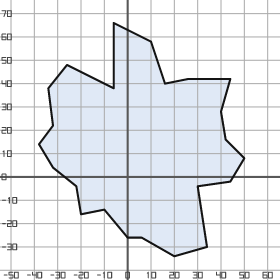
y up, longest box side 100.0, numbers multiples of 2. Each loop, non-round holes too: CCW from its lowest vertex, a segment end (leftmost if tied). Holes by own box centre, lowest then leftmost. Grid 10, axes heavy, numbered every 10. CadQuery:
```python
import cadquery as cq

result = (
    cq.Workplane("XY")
    .moveTo(20.0, -34.0)
    .lineTo(34.0, -30.0)
    .lineTo(30.0, -4.0)
    .lineTo(44.0, -2.0)
    .lineTo(50.0, 8.0)
    .lineTo(42.0, 16.0)
    .lineTo(40.0, 28.0)
    .lineTo(44.0, 42.0)
    .lineTo(26.0, 42.0)
    .lineTo(16.0, 40.0)
    .lineTo(10.0, 58.0)
    .lineTo(-6.0, 66.0)
    .lineTo(-6.0, 38.0)
    .lineTo(-26.0, 48.0)
    .lineTo(-34.0, 38.0)
    .lineTo(-32.0, 22.0)
    .lineTo(-38.0, 14.0)
    .lineTo(-32.0, 4.0)
    .lineTo(-22.0, -4.0)
    .lineTo(-20.0, -16.0)
    .lineTo(-10.0, -14.0)
    .lineTo(0.0, -26.0)
    .lineTo(6.0, -26.0)
    .close()
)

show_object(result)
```